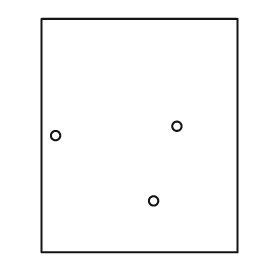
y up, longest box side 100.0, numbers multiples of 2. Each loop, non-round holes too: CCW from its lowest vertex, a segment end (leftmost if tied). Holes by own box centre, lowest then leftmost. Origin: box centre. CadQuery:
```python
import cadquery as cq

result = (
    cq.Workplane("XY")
    .moveTo(-42.0, -50.0)
    .lineTo(42.0, -50.0)
    .lineTo(42.0, 50.0)
    .lineTo(-42.0, 50.0)
    .close()
    .moveTo(6.0, -28.0)
    .circle(2.0)
    .moveTo(-36.0, 0.0)
    .circle(2.0)
    .moveTo(16.0, 4.0)
    .circle(2.0)
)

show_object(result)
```